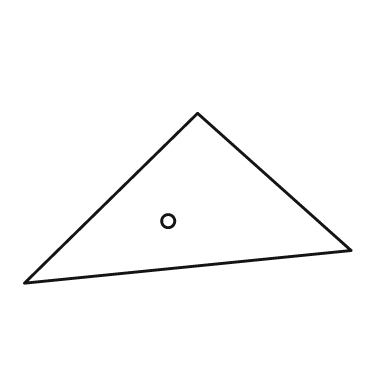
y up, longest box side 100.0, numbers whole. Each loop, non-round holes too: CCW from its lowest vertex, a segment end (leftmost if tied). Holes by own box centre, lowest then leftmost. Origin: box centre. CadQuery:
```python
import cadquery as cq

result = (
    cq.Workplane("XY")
    .moveTo(-50.0, -26.0)
    .lineTo(50.0, -16.0)
    .lineTo(3.0, 26.0)
    .close()
    .moveTo(-6.0, -7.0)
    .circle(2.0)
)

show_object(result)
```